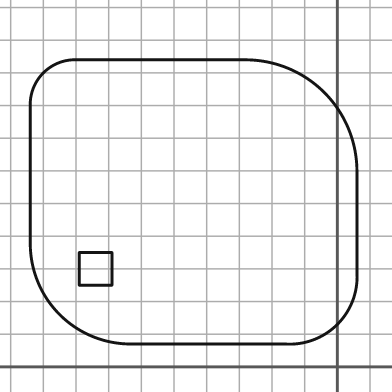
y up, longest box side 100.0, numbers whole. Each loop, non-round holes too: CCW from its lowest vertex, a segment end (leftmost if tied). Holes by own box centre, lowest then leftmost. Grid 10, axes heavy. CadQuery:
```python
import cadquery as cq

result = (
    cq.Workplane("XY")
    .moveTo(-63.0, 7.0)
    .lineTo(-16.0, 7.0)
    .threePointArc((0.0, 13.0), (6.0, 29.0))
    .lineTo(6.0, 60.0)
    .threePointArc((-4.0, 84.0), (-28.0, 94.0))
    .lineTo(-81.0, 94.0)
    .threePointArc((-90.0, 90.0), (-94.0, 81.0))
    .lineTo(-94.0, 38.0)
    .threePointArc((-85.0, 16.0), (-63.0, 7.0))
    .close()
    .moveTo(-79.0, 25.0)
    .lineTo(-69.0, 25.0)
    .lineTo(-69.0, 35.0)
    .lineTo(-79.0, 35.0)
    .close()
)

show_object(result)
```